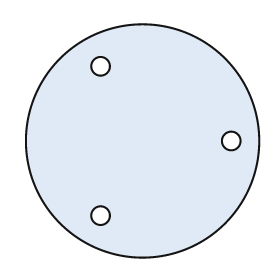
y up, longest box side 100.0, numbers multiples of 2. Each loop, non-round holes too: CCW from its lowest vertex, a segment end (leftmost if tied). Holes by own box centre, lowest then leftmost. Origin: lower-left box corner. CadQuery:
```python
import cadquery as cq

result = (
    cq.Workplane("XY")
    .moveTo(50.0, 50.0)
    .circle(50.0)
    .moveTo(32.0, 18.0)
    .circle(4.0)
    .moveTo(88.0, 50.0)
    .circle(4.0)
    .moveTo(32.0, 82.0)
    .circle(4.0)
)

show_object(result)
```